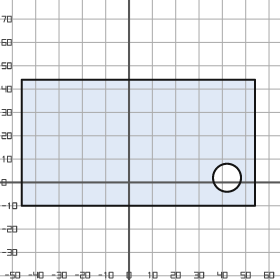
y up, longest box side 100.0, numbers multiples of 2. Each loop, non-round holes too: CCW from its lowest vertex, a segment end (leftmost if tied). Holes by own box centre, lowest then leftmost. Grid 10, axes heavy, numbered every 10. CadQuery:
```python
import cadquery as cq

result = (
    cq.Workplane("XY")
    .moveTo(-46.0, -10.0)
    .lineTo(54.0, -10.0)
    .lineTo(54.0, 44.0)
    .lineTo(-46.0, 44.0)
    .close()
    .moveTo(42.0, 2.0)
    .circle(6.0)
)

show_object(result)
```